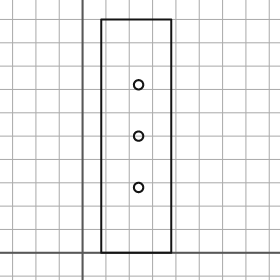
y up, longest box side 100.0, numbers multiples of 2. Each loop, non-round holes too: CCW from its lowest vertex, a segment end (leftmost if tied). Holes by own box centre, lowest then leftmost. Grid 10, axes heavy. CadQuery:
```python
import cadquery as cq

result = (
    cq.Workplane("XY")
    .moveTo(8.0, 0.0)
    .lineTo(38.0, 0.0)
    .lineTo(38.0, 100.0)
    .lineTo(8.0, 100.0)
    .close()
    .moveTo(24.0, 28.0)
    .circle(2.0)
    .moveTo(24.0, 50.0)
    .circle(2.0)
    .moveTo(24.0, 72.0)
    .circle(2.0)
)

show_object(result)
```